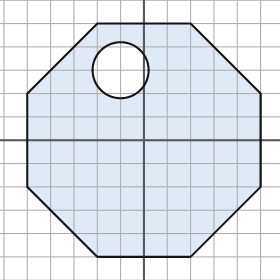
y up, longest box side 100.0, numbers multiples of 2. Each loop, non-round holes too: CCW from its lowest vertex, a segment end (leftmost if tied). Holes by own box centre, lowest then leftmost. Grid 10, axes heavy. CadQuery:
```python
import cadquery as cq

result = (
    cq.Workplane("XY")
    .moveTo(-20.0, -50.0)
    .lineTo(20.0, -50.0)
    .lineTo(50.0, -20.0)
    .lineTo(50.0, 20.0)
    .lineTo(20.0, 50.0)
    .lineTo(-20.0, 50.0)
    .lineTo(-50.0, 20.0)
    .lineTo(-50.0, -20.0)
    .close()
    .moveTo(-10.0, 30.0)
    .circle(12.0)
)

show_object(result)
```